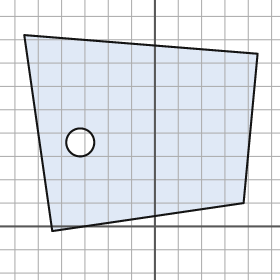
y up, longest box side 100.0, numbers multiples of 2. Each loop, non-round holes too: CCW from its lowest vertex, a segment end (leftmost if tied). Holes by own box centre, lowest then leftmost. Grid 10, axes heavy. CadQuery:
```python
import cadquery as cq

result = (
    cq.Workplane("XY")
    .moveTo(-44.0, -2.0)
    .lineTo(38.0, 10.0)
    .lineTo(44.0, 74.0)
    .lineTo(-56.0, 82.0)
    .close()
    .moveTo(-32.0, 36.0)
    .circle(6.0)
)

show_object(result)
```